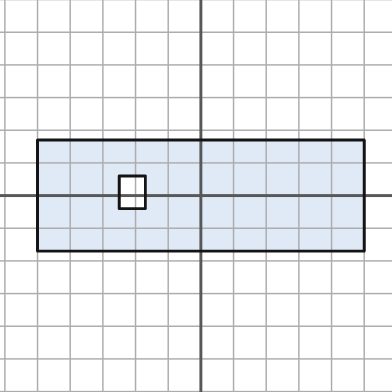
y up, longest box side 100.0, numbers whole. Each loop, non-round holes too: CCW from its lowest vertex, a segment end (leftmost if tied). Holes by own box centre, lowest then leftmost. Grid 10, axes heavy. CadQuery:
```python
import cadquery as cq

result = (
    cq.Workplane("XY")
    .moveTo(-50.0, -17.0)
    .lineTo(50.0, -17.0)
    .lineTo(50.0, 17.0)
    .lineTo(-50.0, 17.0)
    .close()
    .moveTo(-25.0, -4.0)
    .lineTo(-17.0, -4.0)
    .lineTo(-17.0, 6.0)
    .lineTo(-25.0, 6.0)
    .close()
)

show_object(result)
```